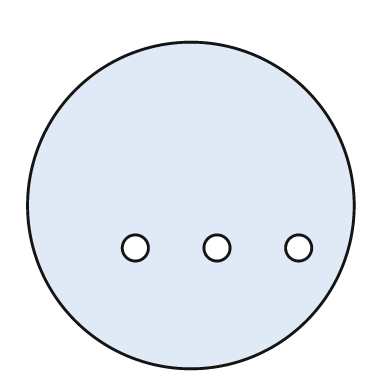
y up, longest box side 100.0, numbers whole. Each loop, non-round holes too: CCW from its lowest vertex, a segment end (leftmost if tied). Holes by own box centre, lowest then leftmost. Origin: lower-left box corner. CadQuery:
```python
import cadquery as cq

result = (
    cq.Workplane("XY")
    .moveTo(50.0, 50.0)
    .circle(50.0)
    .moveTo(33.0, 37.0)
    .circle(4.0)
    .moveTo(58.0, 37.0)
    .circle(4.0)
    .moveTo(83.0, 37.0)
    .circle(4.0)
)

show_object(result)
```